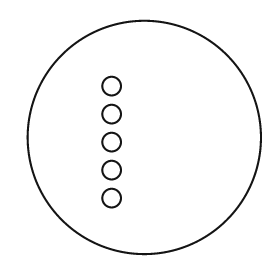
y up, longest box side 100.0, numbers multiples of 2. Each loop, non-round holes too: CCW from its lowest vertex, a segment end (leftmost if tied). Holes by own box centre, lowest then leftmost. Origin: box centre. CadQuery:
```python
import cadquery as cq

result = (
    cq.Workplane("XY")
    .moveTo(0.0, 0.0)
    .circle(50.0)
    .moveTo(-14.0, -26.0)
    .circle(4.0)
    .moveTo(-14.0, -14.0)
    .circle(4.0)
    .moveTo(-14.0, -2.0)
    .circle(4.0)
    .moveTo(-14.0, 10.0)
    .circle(4.0)
    .moveTo(-14.0, 22.0)
    .circle(4.0)
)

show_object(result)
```